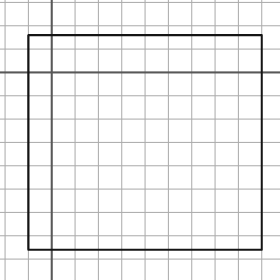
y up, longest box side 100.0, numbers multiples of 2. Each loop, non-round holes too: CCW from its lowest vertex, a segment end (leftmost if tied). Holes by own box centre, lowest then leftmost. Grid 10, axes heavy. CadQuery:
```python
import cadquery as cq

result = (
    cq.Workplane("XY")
    .moveTo(-10.0, -76.0)
    .lineTo(90.0, -76.0)
    .lineTo(90.0, 16.0)
    .lineTo(-10.0, 16.0)
    .close()
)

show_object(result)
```